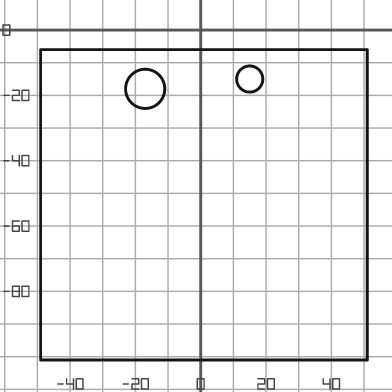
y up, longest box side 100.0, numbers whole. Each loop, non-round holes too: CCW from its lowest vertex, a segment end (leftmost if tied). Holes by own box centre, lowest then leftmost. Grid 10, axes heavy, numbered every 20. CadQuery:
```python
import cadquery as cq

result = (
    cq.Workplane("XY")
    .moveTo(-49.0, -101.0)
    .lineTo(51.0, -101.0)
    .lineTo(51.0, -6.0)
    .lineTo(-49.0, -6.0)
    .close()
    .moveTo(-17.0, -18.0)
    .circle(6.0)
    .moveTo(15.0, -15.0)
    .circle(4.0)
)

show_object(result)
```